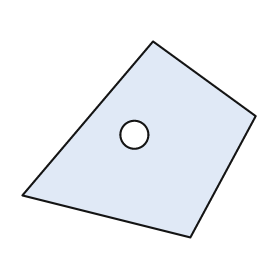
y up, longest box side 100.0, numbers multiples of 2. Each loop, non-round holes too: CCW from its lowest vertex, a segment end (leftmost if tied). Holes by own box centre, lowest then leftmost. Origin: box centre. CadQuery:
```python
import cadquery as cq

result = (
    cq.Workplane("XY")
    .moveTo(22.0, -42.0)
    .lineTo(50.0, 10.0)
    .lineTo(6.0, 42.0)
    .lineTo(-50.0, -24.0)
    .close()
    .moveTo(-2.0, 2.0)
    .circle(6.0)
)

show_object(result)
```